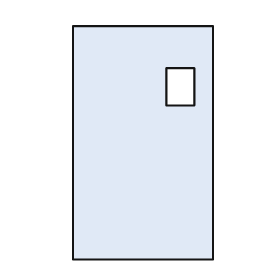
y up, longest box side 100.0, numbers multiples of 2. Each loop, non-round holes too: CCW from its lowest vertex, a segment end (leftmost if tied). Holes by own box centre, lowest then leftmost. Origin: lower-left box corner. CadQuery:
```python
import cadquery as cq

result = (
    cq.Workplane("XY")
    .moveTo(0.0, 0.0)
    .lineTo(60.0, 0.0)
    .lineTo(60.0, 100.0)
    .lineTo(0.0, 100.0)
    .close()
    .moveTo(40.0, 66.0)
    .lineTo(52.0, 66.0)
    .lineTo(52.0, 82.0)
    .lineTo(40.0, 82.0)
    .close()
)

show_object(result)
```